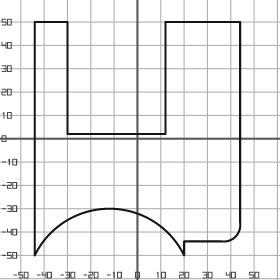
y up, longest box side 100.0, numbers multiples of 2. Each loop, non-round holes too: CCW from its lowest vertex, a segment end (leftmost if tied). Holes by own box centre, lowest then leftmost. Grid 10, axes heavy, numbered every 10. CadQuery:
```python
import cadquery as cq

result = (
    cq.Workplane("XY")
    .moveTo(-44.0, -50.0)
    .threePointArc((-12.0, -30.0), (20.0, -50.0))
    .lineTo(20.0, -44.0)
    .lineTo(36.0, -44.0)
    .threePointArc((42.0, -42.0), (44.0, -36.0))
    .lineTo(44.0, 50.0)
    .lineTo(12.0, 50.0)
    .lineTo(12.0, 2.0)
    .lineTo(-30.0, 2.0)
    .lineTo(-30.0, 50.0)
    .lineTo(-44.0, 50.0)
    .close()
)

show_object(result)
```